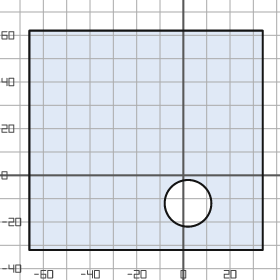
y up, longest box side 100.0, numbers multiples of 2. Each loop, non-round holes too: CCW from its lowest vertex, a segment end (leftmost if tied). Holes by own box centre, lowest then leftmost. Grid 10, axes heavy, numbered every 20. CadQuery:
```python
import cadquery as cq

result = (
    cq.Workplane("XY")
    .moveTo(-66.0, -32.0)
    .lineTo(34.0, -32.0)
    .lineTo(34.0, 62.0)
    .lineTo(-66.0, 62.0)
    .close()
    .moveTo(2.0, -12.0)
    .circle(10.0)
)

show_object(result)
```